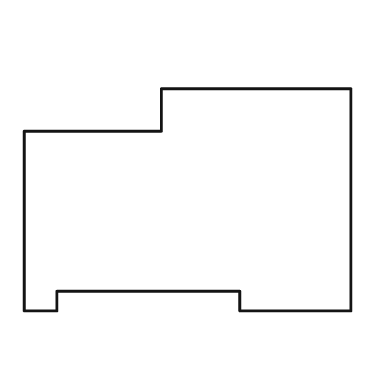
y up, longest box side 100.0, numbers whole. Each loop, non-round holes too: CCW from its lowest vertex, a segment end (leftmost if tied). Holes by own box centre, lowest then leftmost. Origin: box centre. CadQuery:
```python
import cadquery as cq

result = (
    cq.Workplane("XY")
    .moveTo(-50.0, -34.0)
    .lineTo(-40.0, -34.0)
    .lineTo(-40.0, -28.0)
    .lineTo(16.0, -28.0)
    .lineTo(16.0, -34.0)
    .lineTo(50.0, -34.0)
    .lineTo(50.0, 34.0)
    .lineTo(-8.0, 34.0)
    .lineTo(-8.0, 21.0)
    .lineTo(-50.0, 21.0)
    .close()
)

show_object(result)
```